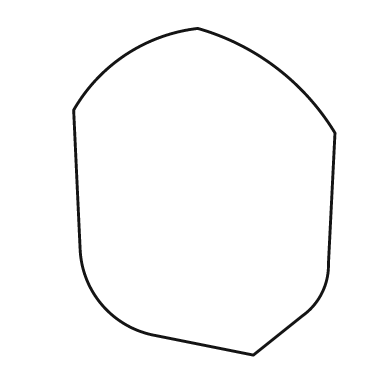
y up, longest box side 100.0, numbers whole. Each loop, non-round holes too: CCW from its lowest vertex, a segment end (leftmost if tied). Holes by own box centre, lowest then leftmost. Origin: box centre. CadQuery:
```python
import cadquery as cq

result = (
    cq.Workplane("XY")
    .moveTo(15.0, -50.0)
    .lineTo(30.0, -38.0)
    .threePointArc((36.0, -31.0), (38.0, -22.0))
    .lineTo(40.0, 18.0)
    .threePointArc((22.0, 38.0), (-2.0, 50.0))
    .threePointArc((-24.0, 42.0), (-40.0, 25.0))
    .lineTo(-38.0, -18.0)
    .threePointArc((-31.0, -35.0), (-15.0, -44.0))
    .close()
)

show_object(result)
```